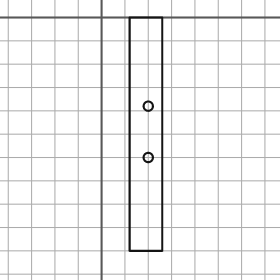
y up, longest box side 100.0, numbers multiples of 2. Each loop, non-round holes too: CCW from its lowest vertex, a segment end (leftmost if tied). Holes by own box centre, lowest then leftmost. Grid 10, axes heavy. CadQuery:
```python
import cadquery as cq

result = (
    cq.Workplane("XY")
    .moveTo(12.0, -100.0)
    .lineTo(26.0, -100.0)
    .lineTo(26.0, 0.0)
    .lineTo(12.0, 0.0)
    .close()
    .moveTo(20.0, -60.0)
    .circle(2.0)
    .moveTo(20.0, -38.0)
    .circle(2.0)
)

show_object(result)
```